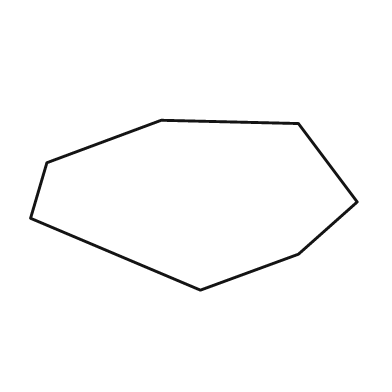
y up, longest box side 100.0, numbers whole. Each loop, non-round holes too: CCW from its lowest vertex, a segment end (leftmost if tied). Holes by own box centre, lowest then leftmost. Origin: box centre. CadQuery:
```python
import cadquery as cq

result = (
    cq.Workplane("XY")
    .moveTo(2.0, -26.0)
    .lineTo(32.0, -15.0)
    .lineTo(50.0, 1.0)
    .lineTo(32.0, 25.0)
    .lineTo(-10.0, 26.0)
    .lineTo(-45.0, 13.0)
    .lineTo(-50.0, -4.0)
    .close()
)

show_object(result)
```